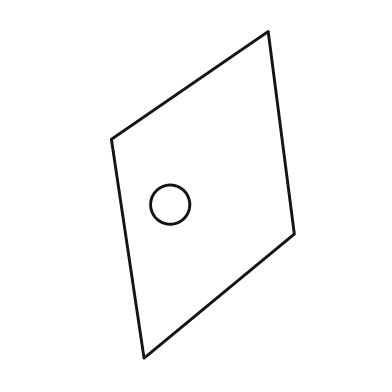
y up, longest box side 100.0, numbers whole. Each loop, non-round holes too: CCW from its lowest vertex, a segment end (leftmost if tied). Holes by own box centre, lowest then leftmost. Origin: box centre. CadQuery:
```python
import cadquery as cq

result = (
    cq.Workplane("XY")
    .moveTo(-18.0, -50.0)
    .lineTo(28.0, -12.0)
    .lineTo(20.0, 50.0)
    .lineTo(-28.0, 17.0)
    .close()
    .moveTo(-10.0, -3.0)
    .circle(6.0)
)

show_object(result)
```